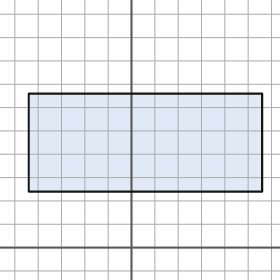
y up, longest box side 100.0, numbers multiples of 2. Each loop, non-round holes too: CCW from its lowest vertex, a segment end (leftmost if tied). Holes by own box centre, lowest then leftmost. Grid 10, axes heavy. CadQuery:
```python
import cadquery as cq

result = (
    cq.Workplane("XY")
    .moveTo(-44.0, 24.0)
    .lineTo(56.0, 24.0)
    .lineTo(56.0, 66.0)
    .lineTo(-44.0, 66.0)
    .close()
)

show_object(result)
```